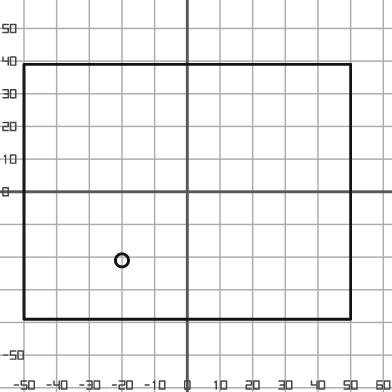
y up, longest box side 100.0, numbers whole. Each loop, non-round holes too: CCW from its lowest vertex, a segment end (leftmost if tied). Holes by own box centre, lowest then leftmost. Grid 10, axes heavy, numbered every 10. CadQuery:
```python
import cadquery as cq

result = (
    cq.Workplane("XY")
    .moveTo(-50.0, -39.0)
    .lineTo(50.0, -39.0)
    .lineTo(50.0, 39.0)
    .lineTo(-50.0, 39.0)
    .close()
    .moveTo(-20.0, -21.0)
    .circle(2.0)
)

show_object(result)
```